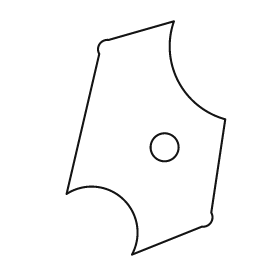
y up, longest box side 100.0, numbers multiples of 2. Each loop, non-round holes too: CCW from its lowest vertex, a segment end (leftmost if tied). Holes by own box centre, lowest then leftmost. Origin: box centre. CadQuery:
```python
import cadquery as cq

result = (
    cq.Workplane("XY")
    .moveTo(-6.0, -50.0)
    .lineTo(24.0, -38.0)
    .threePointArc((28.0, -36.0), (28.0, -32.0))
    .lineTo(34.0, 8.0)
    .threePointArc((14.0, 24.0), (12.0, 50.0))
    .lineTo(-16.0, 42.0)
    .threePointArc((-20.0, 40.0), (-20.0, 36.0))
    .lineTo(-34.0, -24.0)
    .threePointArc((-10.0, -26.0), (-6.0, -50.0))
    .close()
    .moveTo(8.0, -4.0)
    .circle(6.0)
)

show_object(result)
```